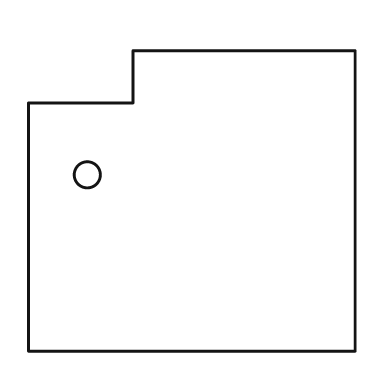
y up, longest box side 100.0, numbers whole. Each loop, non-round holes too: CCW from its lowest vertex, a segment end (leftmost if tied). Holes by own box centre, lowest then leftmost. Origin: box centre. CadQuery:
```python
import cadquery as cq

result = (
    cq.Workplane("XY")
    .moveTo(-50.0, -46.0)
    .lineTo(50.0, -46.0)
    .lineTo(50.0, 46.0)
    .lineTo(-18.0, 46.0)
    .lineTo(-18.0, 30.0)
    .lineTo(-50.0, 30.0)
    .close()
    .moveTo(-32.0, 8.0)
    .circle(4.0)
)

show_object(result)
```